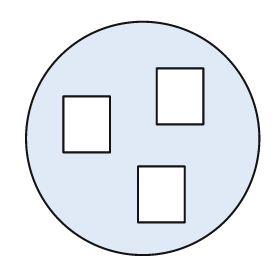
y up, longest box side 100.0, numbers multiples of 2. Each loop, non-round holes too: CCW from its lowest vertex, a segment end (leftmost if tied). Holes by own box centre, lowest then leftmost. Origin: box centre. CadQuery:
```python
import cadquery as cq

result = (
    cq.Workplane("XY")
    .moveTo(0.0, 0.0)
    .circle(50.0)
    .moveTo(-2.0, -36.0)
    .lineTo(18.0, -36.0)
    .lineTo(18.0, -12.0)
    .lineTo(-2.0, -12.0)
    .close()
    .moveTo(-34.0, -6.0)
    .lineTo(-14.0, -6.0)
    .lineTo(-14.0, 18.0)
    .lineTo(-34.0, 18.0)
    .close()
    .moveTo(6.0, 6.0)
    .lineTo(26.0, 6.0)
    .lineTo(26.0, 30.0)
    .lineTo(6.0, 30.0)
    .close()
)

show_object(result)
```